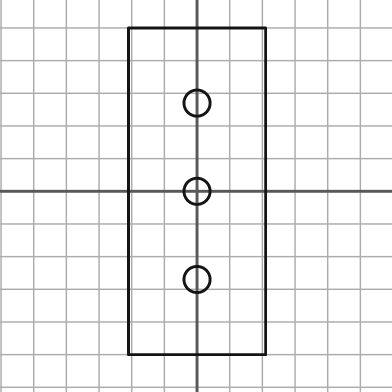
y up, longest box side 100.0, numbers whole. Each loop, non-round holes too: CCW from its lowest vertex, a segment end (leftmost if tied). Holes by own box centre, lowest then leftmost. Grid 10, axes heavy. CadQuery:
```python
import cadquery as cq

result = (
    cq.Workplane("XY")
    .moveTo(-21.0, -50.0)
    .lineTo(21.0, -50.0)
    .lineTo(21.0, 50.0)
    .lineTo(-21.0, 50.0)
    .close()
    .moveTo(0.0, -27.0)
    .circle(4.0)
    .moveTo(0.0, 0.0)
    .circle(4.0)
    .moveTo(0.0, 27.0)
    .circle(4.0)
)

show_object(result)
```